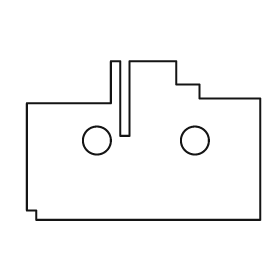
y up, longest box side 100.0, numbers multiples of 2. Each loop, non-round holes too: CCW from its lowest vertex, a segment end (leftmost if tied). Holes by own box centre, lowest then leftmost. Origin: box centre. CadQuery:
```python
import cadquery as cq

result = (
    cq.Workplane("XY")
    .moveTo(-46.0, -34.0)
    .lineTo(50.0, -34.0)
    .lineTo(50.0, 18.0)
    .lineTo(24.0, 18.0)
    .lineTo(24.0, 24.0)
    .lineTo(14.0, 24.0)
    .lineTo(14.0, 34.0)
    .lineTo(-6.0, 34.0)
    .lineTo(-6.0, 2.0)
    .lineTo(-10.0, 2.0)
    .lineTo(-10.0, 34.0)
    .lineTo(-14.0, 34.0)
    .lineTo(-14.0, 16.0)
    .lineTo(-50.0, 16.0)
    .lineTo(-50.0, -30.0)
    .lineTo(-46.0, -30.0)
    .close()
    .moveTo(-20.0, 0.0)
    .circle(6.0)
    .moveTo(22.0, 0.0)
    .circle(6.0)
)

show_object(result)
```